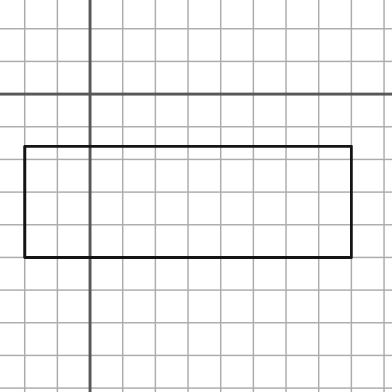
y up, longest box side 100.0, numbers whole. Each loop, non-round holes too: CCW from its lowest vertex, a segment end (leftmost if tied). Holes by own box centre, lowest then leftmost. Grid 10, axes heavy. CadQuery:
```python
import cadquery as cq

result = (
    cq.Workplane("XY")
    .moveTo(-20.0, -50.0)
    .lineTo(80.0, -50.0)
    .lineTo(80.0, -16.0)
    .lineTo(-20.0, -16.0)
    .close()
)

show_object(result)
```